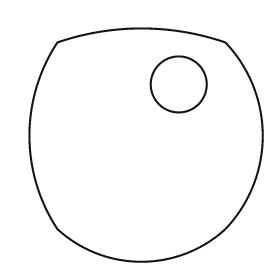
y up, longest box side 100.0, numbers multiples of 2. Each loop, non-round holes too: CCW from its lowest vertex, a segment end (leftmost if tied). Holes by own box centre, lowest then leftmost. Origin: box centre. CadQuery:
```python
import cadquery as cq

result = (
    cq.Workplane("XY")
    .moveTo(-38.0, -36.0)
    .threePointArc((-2.0, -50.0), (34.0, -36.0))
    .threePointArc((50.0, 4.0), (34.0, 44.0))
    .threePointArc((-2.0, 50.0), (-38.0, 44.0))
    .threePointArc((-50.0, 4.0), (-38.0, -36.0))
    .close()
    .moveTo(14.0, 26.0)
    .circle(12.0)
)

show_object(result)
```